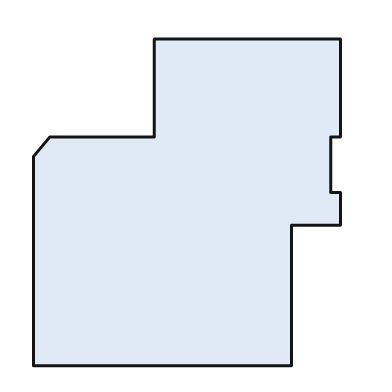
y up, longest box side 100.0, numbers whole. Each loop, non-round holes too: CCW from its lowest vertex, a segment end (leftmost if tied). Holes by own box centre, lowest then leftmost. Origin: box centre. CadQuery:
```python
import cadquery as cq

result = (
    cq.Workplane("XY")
    .moveTo(-47.0, -50.0)
    .lineTo(32.0, -50.0)
    .lineTo(32.0, -7.0)
    .lineTo(47.0, -7.0)
    .lineTo(47.0, 3.0)
    .lineTo(44.0, 3.0)
    .lineTo(44.0, 20.0)
    .lineTo(47.0, 20.0)
    .lineTo(47.0, 50.0)
    .lineTo(-10.0, 50.0)
    .lineTo(-10.0, 20.0)
    .lineTo(-42.0, 20.0)
    .lineTo(-47.0, 14.0)
    .close()
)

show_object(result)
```